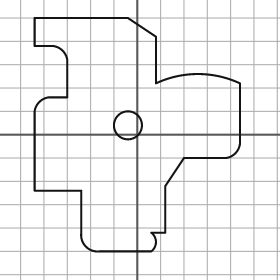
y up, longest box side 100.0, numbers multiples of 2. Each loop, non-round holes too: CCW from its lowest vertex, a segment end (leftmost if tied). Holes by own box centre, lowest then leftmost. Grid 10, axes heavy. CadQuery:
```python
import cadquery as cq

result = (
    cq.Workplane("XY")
    .moveTo(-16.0, -50.0)
    .lineTo(6.0, -50.0)
    .threePointArc((8.0, -46.0), (6.0, -42.0))
    .lineTo(12.0, -42.0)
    .lineTo(12.0, -22.0)
    .lineTo(20.0, -10.0)
    .lineTo(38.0, -10.0)
    .threePointArc((42.0, -8.0), (44.0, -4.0))
    .lineTo(44.0, 22.0)
    .threePointArc((26.0, 26.0), (8.0, 22.0))
    .lineTo(8.0, 42.0)
    .lineTo(-4.0, 50.0)
    .lineTo(-44.0, 50.0)
    .lineTo(-44.0, 38.0)
    .lineTo(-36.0, 38.0)
    .threePointArc((-32.0, 36.0), (-30.0, 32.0))
    .lineTo(-30.0, 16.0)
    .lineTo(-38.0, 16.0)
    .threePointArc((-42.0, 14.0), (-44.0, 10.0))
    .lineTo(-44.0, -24.0)
    .lineTo(-24.0, -24.0)
    .lineTo(-24.0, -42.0)
    .threePointArc((-22.0, -48.0), (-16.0, -50.0))
    .close()
    .moveTo(-4.0, 4.0)
    .circle(6.0)
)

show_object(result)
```